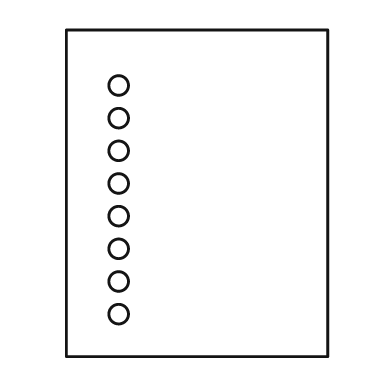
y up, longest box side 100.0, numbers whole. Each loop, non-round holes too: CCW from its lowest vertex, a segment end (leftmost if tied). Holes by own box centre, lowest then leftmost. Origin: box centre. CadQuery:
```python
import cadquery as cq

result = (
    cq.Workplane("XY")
    .moveTo(-40.0, -50.0)
    .lineTo(40.0, -50.0)
    .lineTo(40.0, 50.0)
    .lineTo(-40.0, 50.0)
    .close()
    .moveTo(-24.0, -37.0)
    .circle(3.0)
    .moveTo(-24.0, -27.0)
    .circle(3.0)
    .moveTo(-24.0, -17.0)
    .circle(3.0)
    .moveTo(-24.0, -7.0)
    .circle(3.0)
    .moveTo(-24.0, 3.0)
    .circle(3.0)
    .moveTo(-24.0, 13.0)
    .circle(3.0)
    .moveTo(-24.0, 23.0)
    .circle(3.0)
    .moveTo(-24.0, 33.0)
    .circle(3.0)
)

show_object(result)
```